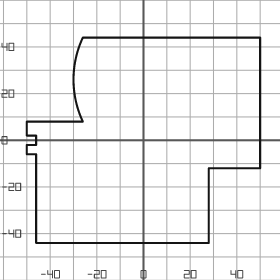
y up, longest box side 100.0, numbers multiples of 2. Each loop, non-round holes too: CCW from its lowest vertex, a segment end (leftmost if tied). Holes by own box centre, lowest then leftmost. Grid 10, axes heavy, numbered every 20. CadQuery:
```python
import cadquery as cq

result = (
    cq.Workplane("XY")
    .moveTo(-46.0, -44.0)
    .lineTo(28.0, -44.0)
    .lineTo(28.0, -12.0)
    .lineTo(50.0, -12.0)
    .lineTo(50.0, 44.0)
    .lineTo(-26.0, 44.0)
    .threePointArc((-30.0, 26.0), (-26.0, 8.0))
    .lineTo(-50.0, 8.0)
    .lineTo(-50.0, 2.0)
    .lineTo(-46.0, 2.0)
    .lineTo(-46.0, -2.0)
    .lineTo(-50.0, -2.0)
    .lineTo(-50.0, -6.0)
    .lineTo(-46.0, -6.0)
    .close()
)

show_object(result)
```